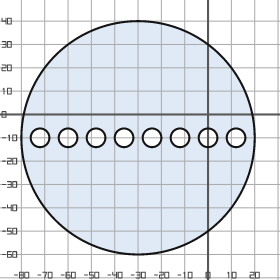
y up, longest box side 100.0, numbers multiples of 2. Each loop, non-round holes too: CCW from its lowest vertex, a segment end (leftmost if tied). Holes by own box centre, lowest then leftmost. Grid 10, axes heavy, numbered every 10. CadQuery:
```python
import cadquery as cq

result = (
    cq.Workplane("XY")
    .moveTo(-30.0, -10.0)
    .circle(50.0)
    .moveTo(-72.0, -10.0)
    .circle(4.0)
    .moveTo(-60.0, -10.0)
    .circle(4.0)
    .moveTo(-48.0, -10.0)
    .circle(4.0)
    .moveTo(-36.0, -10.0)
    .circle(4.0)
    .moveTo(-24.0, -10.0)
    .circle(4.0)
    .moveTo(-12.0, -10.0)
    .circle(4.0)
    .moveTo(0.0, -10.0)
    .circle(4.0)
    .moveTo(12.0, -10.0)
    .circle(4.0)
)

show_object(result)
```